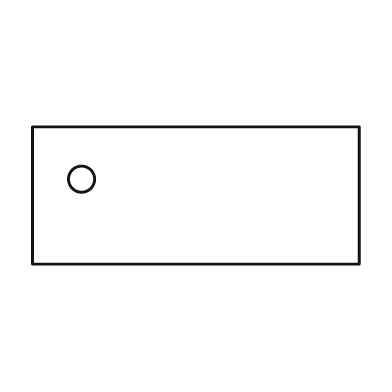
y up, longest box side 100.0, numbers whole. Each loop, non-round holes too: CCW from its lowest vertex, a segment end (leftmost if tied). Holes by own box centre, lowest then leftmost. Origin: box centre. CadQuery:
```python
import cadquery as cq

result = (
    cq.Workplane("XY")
    .moveTo(-50.0, -21.0)
    .lineTo(50.0, -21.0)
    .lineTo(50.0, 21.0)
    .lineTo(-50.0, 21.0)
    .close()
    .moveTo(-35.0, 5.0)
    .circle(4.0)
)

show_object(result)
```